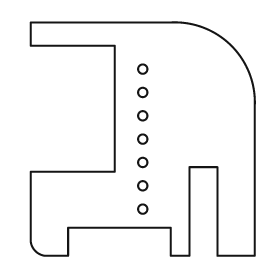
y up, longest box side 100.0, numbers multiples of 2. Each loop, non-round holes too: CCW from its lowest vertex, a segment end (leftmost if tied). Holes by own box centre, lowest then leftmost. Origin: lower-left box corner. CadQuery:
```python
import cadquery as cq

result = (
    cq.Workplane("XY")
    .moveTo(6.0, 0.0)
    .lineTo(16.0, 0.0)
    .lineTo(16.0, 12.0)
    .lineTo(60.0, 12.0)
    .lineTo(60.0, 0.0)
    .lineTo(68.0, 0.0)
    .lineTo(68.0, 38.0)
    .lineTo(80.0, 38.0)
    .lineTo(80.0, 0.0)
    .lineTo(96.0, 0.0)
    .lineTo(96.0, 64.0)
    .threePointArc((86.0, 90.0), (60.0, 100.0))
    .lineTo(0.0, 100.0)
    .lineTo(0.0, 90.0)
    .lineTo(36.0, 90.0)
    .lineTo(36.0, 36.0)
    .lineTo(0.0, 36.0)
    .lineTo(0.0, 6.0)
    .threePointArc((2.0, 2.0), (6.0, 0.0))
    .close()
    .moveTo(48.0, 20.0)
    .circle(2.0)
    .moveTo(48.0, 30.0)
    .circle(2.0)
    .moveTo(48.0, 40.0)
    .circle(2.0)
    .moveTo(48.0, 50.0)
    .circle(2.0)
    .moveTo(48.0, 60.0)
    .circle(2.0)
    .moveTo(48.0, 70.0)
    .circle(2.0)
    .moveTo(48.0, 80.0)
    .circle(2.0)
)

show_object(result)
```